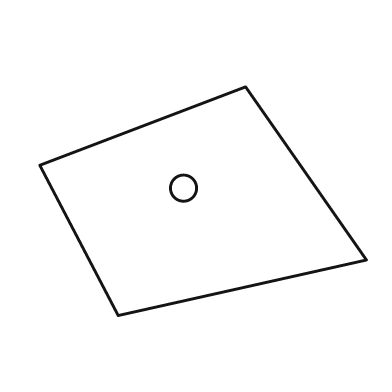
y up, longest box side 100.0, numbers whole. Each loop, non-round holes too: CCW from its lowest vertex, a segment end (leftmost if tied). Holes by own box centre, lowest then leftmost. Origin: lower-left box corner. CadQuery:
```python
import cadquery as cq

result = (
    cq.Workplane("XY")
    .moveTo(24.0, 0.0)
    .lineTo(100.0, 17.0)
    .lineTo(63.0, 70.0)
    .lineTo(0.0, 46.0)
    .close()
    .moveTo(44.0, 39.0)
    .circle(4.0)
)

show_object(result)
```